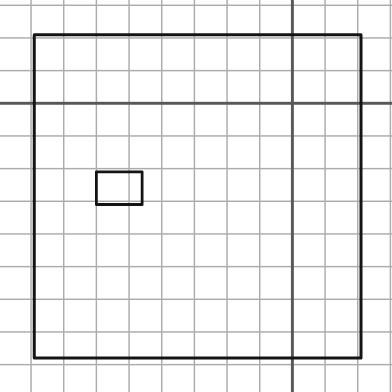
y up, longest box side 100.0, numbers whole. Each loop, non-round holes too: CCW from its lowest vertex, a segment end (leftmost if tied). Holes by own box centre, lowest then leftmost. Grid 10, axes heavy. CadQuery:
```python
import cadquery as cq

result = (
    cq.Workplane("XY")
    .moveTo(-79.0, -78.0)
    .lineTo(21.0, -78.0)
    .lineTo(21.0, 21.0)
    .lineTo(-79.0, 21.0)
    .close()
    .moveTo(-60.0, -31.0)
    .lineTo(-46.0, -31.0)
    .lineTo(-46.0, -21.0)
    .lineTo(-60.0, -21.0)
    .close()
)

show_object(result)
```